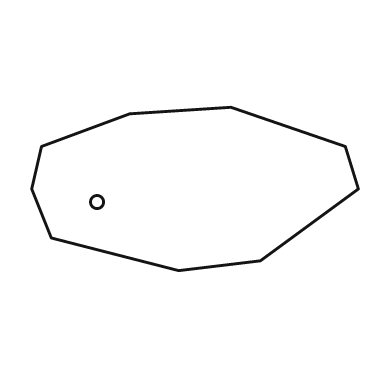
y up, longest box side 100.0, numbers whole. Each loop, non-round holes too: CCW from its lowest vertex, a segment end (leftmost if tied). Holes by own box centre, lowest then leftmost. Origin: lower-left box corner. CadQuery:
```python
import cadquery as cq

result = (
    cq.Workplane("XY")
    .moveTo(45.0, 0.0)
    .lineTo(70.0, 3.0)
    .lineTo(100.0, 25.0)
    .lineTo(96.0, 38.0)
    .lineTo(61.0, 50.0)
    .lineTo(30.0, 48.0)
    .lineTo(3.0, 38.0)
    .lineTo(0.0, 25.0)
    .lineTo(6.0, 10.0)
    .close()
    .moveTo(20.0, 21.0)
    .circle(2.0)
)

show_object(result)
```